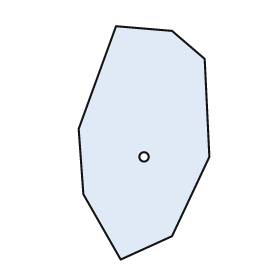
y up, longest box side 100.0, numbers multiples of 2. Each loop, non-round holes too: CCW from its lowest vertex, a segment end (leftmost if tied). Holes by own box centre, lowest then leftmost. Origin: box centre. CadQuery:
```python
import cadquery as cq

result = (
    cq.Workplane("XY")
    .moveTo(-10.0, -50.0)
    .lineTo(12.0, -40.0)
    .lineTo(28.0, -6.0)
    .lineTo(26.0, 36.0)
    .lineTo(12.0, 48.0)
    .lineTo(-12.0, 50.0)
    .lineTo(-28.0, 6.0)
    .lineTo(-26.0, -22.0)
    .close()
    .moveTo(0.0, -6.0)
    .circle(2.0)
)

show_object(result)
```